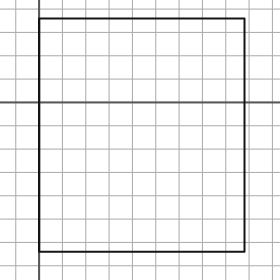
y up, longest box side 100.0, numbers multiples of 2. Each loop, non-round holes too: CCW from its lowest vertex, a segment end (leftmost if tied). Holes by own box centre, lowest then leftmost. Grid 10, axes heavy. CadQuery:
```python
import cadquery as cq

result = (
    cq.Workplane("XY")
    .moveTo(0.0, -64.0)
    .lineTo(88.0, -64.0)
    .lineTo(88.0, 36.0)
    .lineTo(0.0, 36.0)
    .close()
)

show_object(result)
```